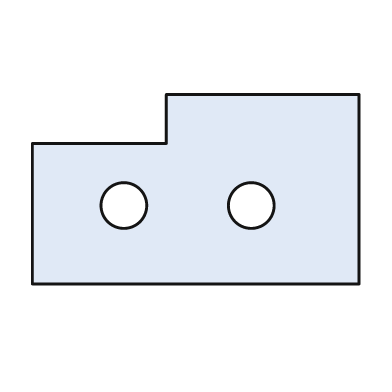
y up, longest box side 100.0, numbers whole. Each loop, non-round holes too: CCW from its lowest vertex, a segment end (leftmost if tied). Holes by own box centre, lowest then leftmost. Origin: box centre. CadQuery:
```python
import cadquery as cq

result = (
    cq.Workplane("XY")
    .moveTo(-50.0, -29.0)
    .lineTo(50.0, -29.0)
    .lineTo(50.0, 29.0)
    .lineTo(-9.0, 29.0)
    .lineTo(-9.0, 14.0)
    .lineTo(-50.0, 14.0)
    .close()
    .moveTo(-22.0, -5.0)
    .circle(7.0)
    .moveTo(17.0, -5.0)
    .circle(7.0)
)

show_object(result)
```